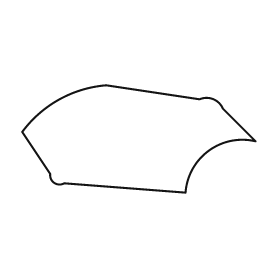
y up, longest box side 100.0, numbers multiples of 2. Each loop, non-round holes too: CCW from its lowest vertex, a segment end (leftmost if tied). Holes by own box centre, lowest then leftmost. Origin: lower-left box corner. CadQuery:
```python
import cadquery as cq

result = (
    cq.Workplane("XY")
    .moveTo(70.0, 0.0)
    .threePointArc((80.0, 18.0), (100.0, 22.0))
    .lineTo(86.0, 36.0)
    .threePointArc((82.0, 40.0), (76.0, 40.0))
    .lineTo(36.0, 46.0)
    .threePointArc((16.0, 40.0), (0.0, 26.0))
    .lineTo(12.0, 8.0)
    .threePointArc((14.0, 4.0), (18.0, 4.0))
    .close()
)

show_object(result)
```